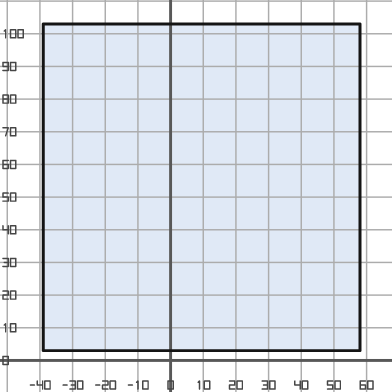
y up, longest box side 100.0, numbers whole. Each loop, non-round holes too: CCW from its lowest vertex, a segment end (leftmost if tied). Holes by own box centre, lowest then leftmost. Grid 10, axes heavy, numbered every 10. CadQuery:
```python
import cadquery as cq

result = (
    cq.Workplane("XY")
    .moveTo(-39.0, 3.0)
    .lineTo(58.0, 3.0)
    .lineTo(58.0, 103.0)
    .lineTo(-39.0, 103.0)
    .close()
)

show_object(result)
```